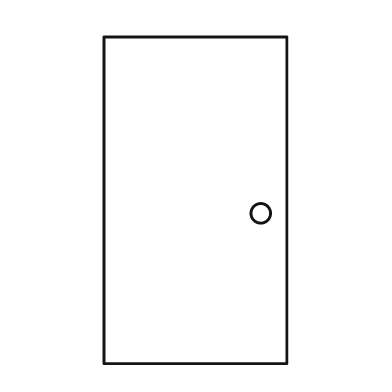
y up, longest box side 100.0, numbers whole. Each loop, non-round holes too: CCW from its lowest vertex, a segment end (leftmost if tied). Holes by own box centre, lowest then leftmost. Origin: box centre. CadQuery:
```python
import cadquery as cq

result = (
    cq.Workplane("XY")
    .moveTo(-28.0, -50.0)
    .lineTo(28.0, -50.0)
    .lineTo(28.0, 50.0)
    .lineTo(-28.0, 50.0)
    .close()
    .moveTo(20.0, -4.0)
    .circle(3.0)
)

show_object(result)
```